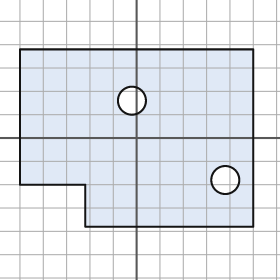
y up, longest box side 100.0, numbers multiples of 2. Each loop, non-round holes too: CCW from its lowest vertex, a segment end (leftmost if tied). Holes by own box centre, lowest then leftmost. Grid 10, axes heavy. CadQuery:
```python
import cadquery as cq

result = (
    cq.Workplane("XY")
    .moveTo(-22.0, -38.0)
    .lineTo(50.0, -38.0)
    .lineTo(50.0, 38.0)
    .lineTo(-50.0, 38.0)
    .lineTo(-50.0, -20.0)
    .lineTo(-22.0, -20.0)
    .close()
    .moveTo(38.0, -18.0)
    .circle(6.0)
    .moveTo(-2.0, 16.0)
    .circle(6.0)
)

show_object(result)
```